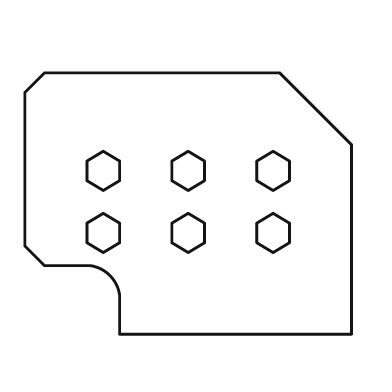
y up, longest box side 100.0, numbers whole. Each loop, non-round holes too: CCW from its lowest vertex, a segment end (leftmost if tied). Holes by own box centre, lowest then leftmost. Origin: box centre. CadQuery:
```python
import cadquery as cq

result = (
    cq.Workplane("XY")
    .moveTo(-21.0, -40.0)
    .lineTo(50.0, -40.0)
    .lineTo(50.0, 18.0)
    .lineTo(28.0, 40.0)
    .lineTo(-44.0, 40.0)
    .lineTo(-50.0, 34.0)
    .lineTo(-50.0, -13.0)
    .lineTo(-44.0, -19.0)
    .lineTo(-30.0, -19.0)
    .threePointArc((-24.0, -22.0), (-21.0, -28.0))
    .close()
    .moveTo(-26.0, -15.0)
    .lineTo(-21.0, -12.0)
    .lineTo(-21.0, -6.0)
    .lineTo(-26.0, -3.0)
    .lineTo(-31.0, -6.0)
    .lineTo(-31.0, -12.0)
    .close()
    .moveTo(0.0, -15.0)
    .lineTo(5.0, -12.0)
    .lineTo(5.0, -6.0)
    .lineTo(0.0, -3.0)
    .lineTo(-5.0, -6.0)
    .lineTo(-5.0, -12.0)
    .close()
    .moveTo(26.0, -15.0)
    .lineTo(31.0, -12.0)
    .lineTo(31.0, -6.0)
    .lineTo(26.0, -3.0)
    .lineTo(21.0, -6.0)
    .lineTo(21.0, -12.0)
    .close()
    .moveTo(-26.0, 4.0)
    .lineTo(-21.0, 7.0)
    .lineTo(-21.0, 13.0)
    .lineTo(-26.0, 16.0)
    .lineTo(-31.0, 13.0)
    .lineTo(-31.0, 7.0)
    .close()
    .moveTo(0.0, 4.0)
    .lineTo(5.0, 7.0)
    .lineTo(5.0, 13.0)
    .lineTo(0.0, 16.0)
    .lineTo(-5.0, 13.0)
    .lineTo(-5.0, 7.0)
    .close()
    .moveTo(26.0, 4.0)
    .lineTo(31.0, 7.0)
    .lineTo(31.0, 13.0)
    .lineTo(26.0, 16.0)
    .lineTo(21.0, 13.0)
    .lineTo(21.0, 7.0)
    .close()
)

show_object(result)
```